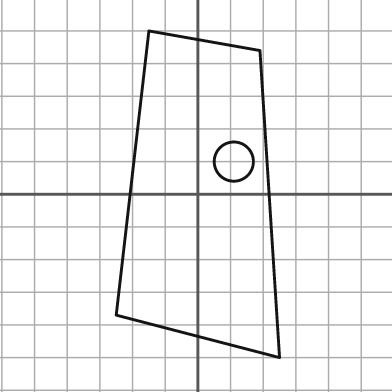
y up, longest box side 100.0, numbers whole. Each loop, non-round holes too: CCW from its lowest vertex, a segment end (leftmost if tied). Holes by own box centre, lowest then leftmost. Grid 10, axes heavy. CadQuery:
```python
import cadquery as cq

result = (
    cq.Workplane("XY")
    .moveTo(25.0, -50.0)
    .lineTo(19.0, 44.0)
    .lineTo(-15.0, 50.0)
    .lineTo(-25.0, -37.0)
    .close()
    .moveTo(11.0, 10.0)
    .circle(6.0)
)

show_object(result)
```